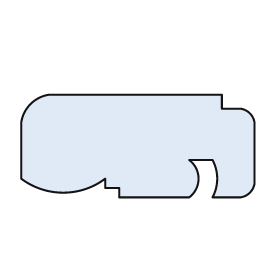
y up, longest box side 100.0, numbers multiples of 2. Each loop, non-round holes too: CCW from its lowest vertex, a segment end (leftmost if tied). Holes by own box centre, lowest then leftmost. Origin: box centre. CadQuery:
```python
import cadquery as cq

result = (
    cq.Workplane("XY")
    .moveTo(-8.0, -22.0)
    .lineTo(22.0, -22.0)
    .threePointArc((26.0, -14.0), (22.0, -6.0))
    .lineTo(32.0, -6.0)
    .threePointArc((34.0, -14.0), (32.0, -22.0))
    .lineTo(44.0, -22.0)
    .threePointArc((48.0, -20.0), (50.0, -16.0))
    .lineTo(50.0, 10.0)
    .threePointArc((48.0, 14.0), (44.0, 16.0))
    .lineTo(36.0, 16.0)
    .lineTo(36.0, 22.0)
    .lineTo(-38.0, 22.0)
    .threePointArc((-46.0, 18.0), (-50.0, 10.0))
    .lineTo(-50.0, -14.0)
    .threePointArc((-32.0, -20.0), (-14.0, -14.0))
    .lineTo(-14.0, -18.0)
    .lineTo(-8.0, -18.0)
    .close()
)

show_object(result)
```